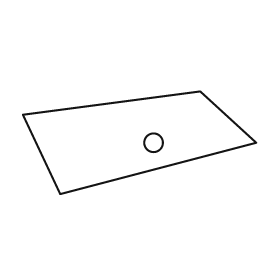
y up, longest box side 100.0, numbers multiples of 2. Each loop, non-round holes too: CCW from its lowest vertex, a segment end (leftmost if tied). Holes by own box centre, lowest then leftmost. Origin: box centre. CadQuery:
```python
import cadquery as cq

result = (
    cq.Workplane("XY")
    .moveTo(-34.0, -22.0)
    .lineTo(50.0, 0.0)
    .lineTo(26.0, 22.0)
    .lineTo(-50.0, 12.0)
    .close()
    .moveTo(6.0, 0.0)
    .circle(4.0)
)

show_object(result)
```